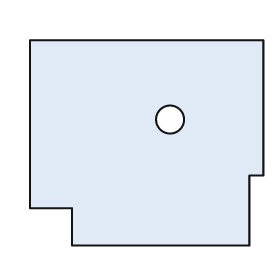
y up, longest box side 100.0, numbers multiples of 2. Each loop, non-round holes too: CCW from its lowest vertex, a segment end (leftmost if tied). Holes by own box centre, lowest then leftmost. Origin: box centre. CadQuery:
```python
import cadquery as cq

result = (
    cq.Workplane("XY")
    .moveTo(-32.0, -44.0)
    .lineTo(44.0, -44.0)
    .lineTo(44.0, -14.0)
    .lineTo(50.0, -14.0)
    .lineTo(50.0, 44.0)
    .lineTo(-50.0, 44.0)
    .lineTo(-50.0, -28.0)
    .lineTo(-32.0, -28.0)
    .close()
    .moveTo(10.0, 10.0)
    .circle(6.0)
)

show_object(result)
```